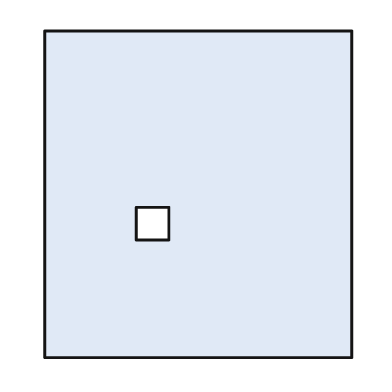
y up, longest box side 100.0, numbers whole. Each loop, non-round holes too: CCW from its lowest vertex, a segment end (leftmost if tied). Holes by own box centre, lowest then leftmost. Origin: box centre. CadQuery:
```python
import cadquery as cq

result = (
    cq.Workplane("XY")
    .moveTo(-47.0, -50.0)
    .lineTo(47.0, -50.0)
    .lineTo(47.0, 50.0)
    .lineTo(-47.0, 50.0)
    .close()
    .moveTo(-19.0, -14.0)
    .lineTo(-9.0, -14.0)
    .lineTo(-9.0, -4.0)
    .lineTo(-19.0, -4.0)
    .close()
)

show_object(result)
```